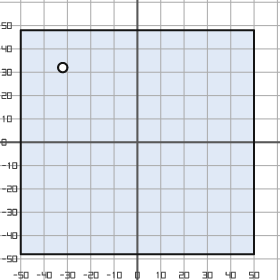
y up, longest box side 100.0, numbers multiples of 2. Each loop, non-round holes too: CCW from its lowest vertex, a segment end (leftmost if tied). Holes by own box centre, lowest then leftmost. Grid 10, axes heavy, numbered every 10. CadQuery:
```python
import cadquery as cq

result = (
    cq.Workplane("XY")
    .moveTo(-50.0, -48.0)
    .lineTo(50.0, -48.0)
    .lineTo(50.0, 48.0)
    .lineTo(-50.0, 48.0)
    .close()
    .moveTo(-32.0, 32.0)
    .circle(2.0)
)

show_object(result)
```